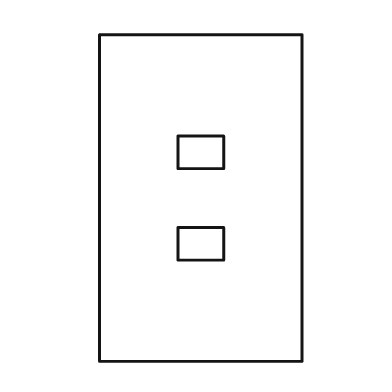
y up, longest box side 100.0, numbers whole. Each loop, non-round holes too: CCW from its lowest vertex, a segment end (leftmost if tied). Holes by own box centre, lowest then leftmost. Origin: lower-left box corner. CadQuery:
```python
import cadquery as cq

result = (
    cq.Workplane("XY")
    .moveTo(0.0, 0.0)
    .lineTo(62.0, 0.0)
    .lineTo(62.0, 100.0)
    .lineTo(0.0, 100.0)
    .close()
    .moveTo(24.0, 31.0)
    .lineTo(38.0, 31.0)
    .lineTo(38.0, 41.0)
    .lineTo(24.0, 41.0)
    .close()
    .moveTo(24.0, 59.0)
    .lineTo(38.0, 59.0)
    .lineTo(38.0, 69.0)
    .lineTo(24.0, 69.0)
    .close()
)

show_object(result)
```